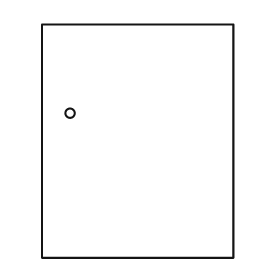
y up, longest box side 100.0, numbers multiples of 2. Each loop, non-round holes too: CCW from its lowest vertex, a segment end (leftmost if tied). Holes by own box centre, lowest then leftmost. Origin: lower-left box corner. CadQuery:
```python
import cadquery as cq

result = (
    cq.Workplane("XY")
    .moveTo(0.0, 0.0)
    .lineTo(82.0, 0.0)
    .lineTo(82.0, 100.0)
    .lineTo(0.0, 100.0)
    .close()
    .moveTo(12.0, 62.0)
    .circle(2.0)
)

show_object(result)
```